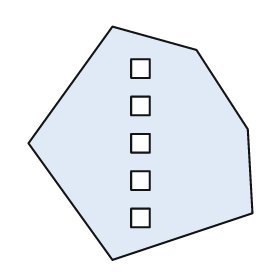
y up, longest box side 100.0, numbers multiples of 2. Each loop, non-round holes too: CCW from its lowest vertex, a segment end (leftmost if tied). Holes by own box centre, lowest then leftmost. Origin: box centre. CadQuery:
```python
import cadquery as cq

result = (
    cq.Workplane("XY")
    .moveTo(-12.0, -50.0)
    .lineTo(48.0, -30.0)
    .lineTo(46.0, 6.0)
    .lineTo(24.0, 40.0)
    .lineTo(-12.0, 50.0)
    .lineTo(-48.0, 0.0)
    .close()
    .moveTo(-4.0, -36.0)
    .lineTo(4.0, -36.0)
    .lineTo(4.0, -28.0)
    .lineTo(-4.0, -28.0)
    .close()
    .moveTo(-4.0, -20.0)
    .lineTo(4.0, -20.0)
    .lineTo(4.0, -12.0)
    .lineTo(-4.0, -12.0)
    .close()
    .moveTo(-4.0, -4.0)
    .lineTo(4.0, -4.0)
    .lineTo(4.0, 4.0)
    .lineTo(-4.0, 4.0)
    .close()
    .moveTo(-4.0, 12.0)
    .lineTo(4.0, 12.0)
    .lineTo(4.0, 20.0)
    .lineTo(-4.0, 20.0)
    .close()
    .moveTo(-4.0, 28.0)
    .lineTo(4.0, 28.0)
    .lineTo(4.0, 36.0)
    .lineTo(-4.0, 36.0)
    .close()
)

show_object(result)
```